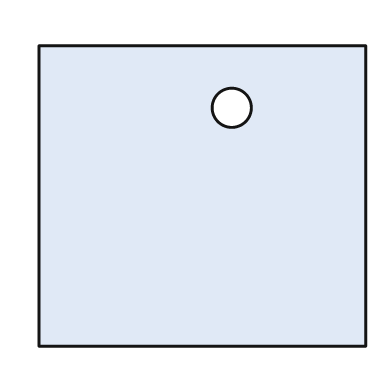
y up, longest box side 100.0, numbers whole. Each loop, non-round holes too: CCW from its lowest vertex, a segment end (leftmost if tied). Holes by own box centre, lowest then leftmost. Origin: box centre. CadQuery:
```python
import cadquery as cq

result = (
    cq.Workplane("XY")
    .moveTo(-50.0, -46.0)
    .lineTo(50.0, -46.0)
    .lineTo(50.0, 46.0)
    .lineTo(-50.0, 46.0)
    .close()
    .moveTo(9.0, 27.0)
    .circle(6.0)
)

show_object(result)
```